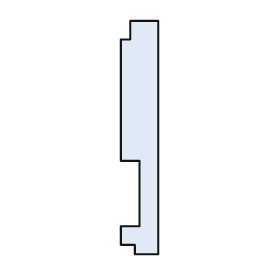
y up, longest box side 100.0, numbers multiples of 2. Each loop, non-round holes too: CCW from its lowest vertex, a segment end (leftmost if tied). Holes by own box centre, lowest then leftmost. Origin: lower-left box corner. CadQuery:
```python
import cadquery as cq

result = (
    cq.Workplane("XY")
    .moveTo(6.0, 0.0)
    .lineTo(16.0, 0.0)
    .lineTo(16.0, 100.0)
    .lineTo(4.0, 100.0)
    .lineTo(4.0, 92.0)
    .lineTo(0.0, 92.0)
    .lineTo(0.0, 40.0)
    .lineTo(8.0, 40.0)
    .lineTo(8.0, 12.0)
    .lineTo(0.0, 12.0)
    .lineTo(0.0, 4.0)
    .lineTo(6.0, 4.0)
    .close()
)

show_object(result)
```